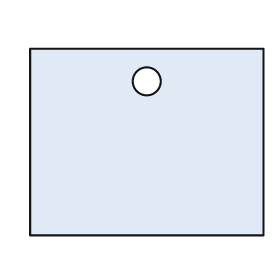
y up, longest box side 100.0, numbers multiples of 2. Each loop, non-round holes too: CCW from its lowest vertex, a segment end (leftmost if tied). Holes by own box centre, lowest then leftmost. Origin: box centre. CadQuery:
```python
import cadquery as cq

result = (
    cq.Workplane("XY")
    .moveTo(-50.0, -40.0)
    .lineTo(50.0, -40.0)
    .lineTo(50.0, 40.0)
    .lineTo(-50.0, 40.0)
    .close()
    .moveTo(0.0, 26.0)
    .circle(6.0)
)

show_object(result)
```